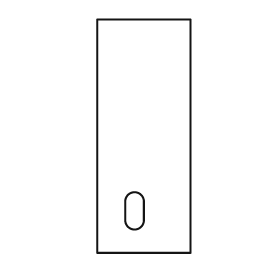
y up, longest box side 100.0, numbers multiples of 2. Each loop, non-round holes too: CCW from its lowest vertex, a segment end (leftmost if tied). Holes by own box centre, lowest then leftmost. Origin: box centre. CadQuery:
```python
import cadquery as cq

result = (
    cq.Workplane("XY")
    .moveTo(-20.0, -50.0)
    .lineTo(20.0, -50.0)
    .lineTo(20.0, 50.0)
    .lineTo(-20.0, 50.0)
    .close()
    .moveTo(-8.0, -36.0)
    .threePointArc((-4.0, -40.0), (0.0, -36.0))
    .lineTo(0.0, -28.0)
    .threePointArc((-4.0, -24.0), (-8.0, -28.0))
    .close()
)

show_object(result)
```